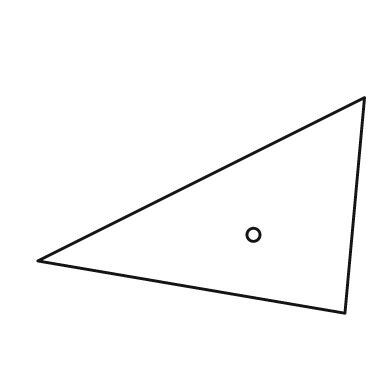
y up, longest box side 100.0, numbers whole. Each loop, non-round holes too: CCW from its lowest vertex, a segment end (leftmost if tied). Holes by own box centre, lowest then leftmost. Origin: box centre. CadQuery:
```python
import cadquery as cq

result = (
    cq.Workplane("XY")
    .moveTo(44.0, -33.0)
    .lineTo(50.0, 33.0)
    .lineTo(-50.0, -17.0)
    .close()
    .moveTo(16.0, -9.0)
    .circle(2.0)
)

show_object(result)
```